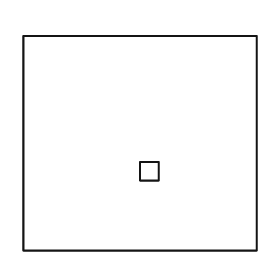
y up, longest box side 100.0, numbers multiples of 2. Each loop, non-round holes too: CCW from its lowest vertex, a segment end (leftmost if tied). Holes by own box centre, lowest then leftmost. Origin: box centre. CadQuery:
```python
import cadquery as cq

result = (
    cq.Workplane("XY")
    .moveTo(-50.0, -46.0)
    .lineTo(50.0, -46.0)
    .lineTo(50.0, 46.0)
    .lineTo(-50.0, 46.0)
    .close()
    .moveTo(0.0, -16.0)
    .lineTo(8.0, -16.0)
    .lineTo(8.0, -8.0)
    .lineTo(0.0, -8.0)
    .close()
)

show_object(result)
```